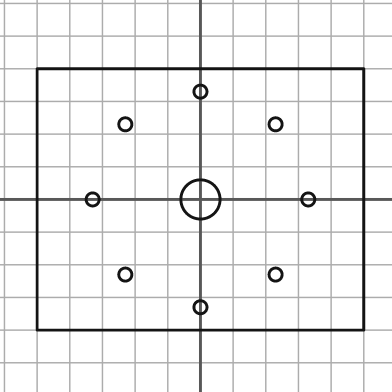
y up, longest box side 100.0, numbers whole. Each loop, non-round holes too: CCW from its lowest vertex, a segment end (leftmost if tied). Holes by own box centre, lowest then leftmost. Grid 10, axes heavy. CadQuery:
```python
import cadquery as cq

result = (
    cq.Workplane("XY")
    .moveTo(-50.0, -40.0)
    .lineTo(50.0, -40.0)
    .lineTo(50.0, 40.0)
    .lineTo(-50.0, 40.0)
    .close()
    .moveTo(0.0, -33.0)
    .circle(2.0)
    .moveTo(-23.0, -23.0)
    .circle(2.0)
    .moveTo(23.0, -23.0)
    .circle(2.0)
    .moveTo(-33.0, 0.0)
    .circle(2.0)
    .moveTo(0.0, 0.0)
    .circle(6.0)
    .moveTo(33.0, 0.0)
    .circle(2.0)
    .moveTo(-23.0, 23.0)
    .circle(2.0)
    .moveTo(23.0, 23.0)
    .circle(2.0)
    .moveTo(0.0, 33.0)
    .circle(2.0)
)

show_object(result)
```